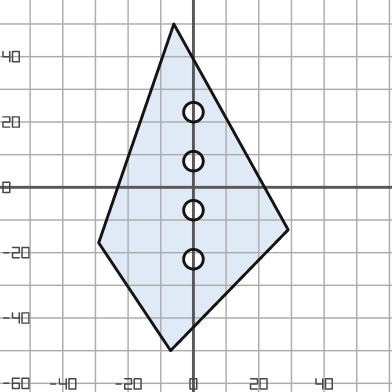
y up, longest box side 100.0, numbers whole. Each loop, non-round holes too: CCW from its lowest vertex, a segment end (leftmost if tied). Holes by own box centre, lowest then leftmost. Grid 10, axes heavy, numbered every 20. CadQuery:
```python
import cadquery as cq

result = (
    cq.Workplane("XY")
    .moveTo(-7.0, -50.0)
    .lineTo(29.0, -13.0)
    .lineTo(-6.0, 50.0)
    .lineTo(-29.0, -17.0)
    .close()
    .moveTo(0.0, -22.0)
    .circle(3.0)
    .moveTo(0.0, -7.0)
    .circle(3.0)
    .moveTo(0.0, 8.0)
    .circle(3.0)
    .moveTo(0.0, 23.0)
    .circle(3.0)
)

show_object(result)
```